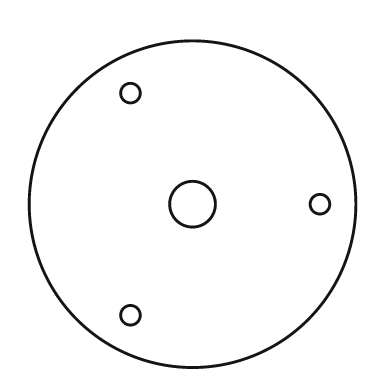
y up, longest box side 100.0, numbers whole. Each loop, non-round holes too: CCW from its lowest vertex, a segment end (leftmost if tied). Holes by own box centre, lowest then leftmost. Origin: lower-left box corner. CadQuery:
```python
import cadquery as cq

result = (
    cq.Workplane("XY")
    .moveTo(50.0, 50.0)
    .circle(50.0)
    .moveTo(31.0, 16.0)
    .circle(3.0)
    .moveTo(50.0, 50.0)
    .circle(7.0)
    .moveTo(89.0, 50.0)
    .circle(3.0)
    .moveTo(31.0, 84.0)
    .circle(3.0)
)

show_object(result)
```